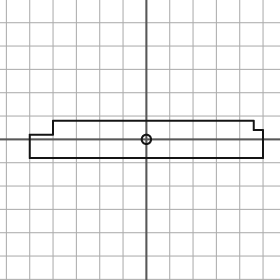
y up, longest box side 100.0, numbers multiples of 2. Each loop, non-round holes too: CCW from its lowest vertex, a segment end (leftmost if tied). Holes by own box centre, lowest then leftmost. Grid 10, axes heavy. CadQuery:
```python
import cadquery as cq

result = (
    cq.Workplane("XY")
    .moveTo(-50.0, -8.0)
    .lineTo(50.0, -8.0)
    .lineTo(50.0, 4.0)
    .lineTo(46.0, 4.0)
    .lineTo(46.0, 8.0)
    .lineTo(-40.0, 8.0)
    .lineTo(-40.0, 2.0)
    .lineTo(-50.0, 2.0)
    .close()
    .moveTo(0.0, 0.0)
    .circle(2.0)
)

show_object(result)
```